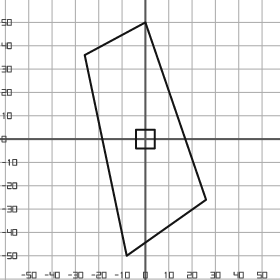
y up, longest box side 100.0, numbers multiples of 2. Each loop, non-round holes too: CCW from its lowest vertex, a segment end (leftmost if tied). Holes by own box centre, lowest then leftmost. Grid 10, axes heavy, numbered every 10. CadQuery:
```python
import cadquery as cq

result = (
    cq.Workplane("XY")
    .moveTo(-8.0, -50.0)
    .lineTo(26.0, -26.0)
    .lineTo(0.0, 50.0)
    .lineTo(-26.0, 36.0)
    .close()
    .moveTo(-4.0, -4.0)
    .lineTo(4.0, -4.0)
    .lineTo(4.0, 4.0)
    .lineTo(-4.0, 4.0)
    .close()
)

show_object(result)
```